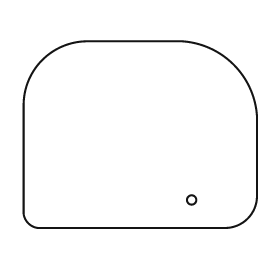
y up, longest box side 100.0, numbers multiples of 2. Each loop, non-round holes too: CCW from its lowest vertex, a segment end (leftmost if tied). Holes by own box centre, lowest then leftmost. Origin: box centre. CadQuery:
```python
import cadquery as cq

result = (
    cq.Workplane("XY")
    .moveTo(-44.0, -40.0)
    .lineTo(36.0, -40.0)
    .threePointArc((46.0, -36.0), (50.0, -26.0))
    .lineTo(50.0, 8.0)
    .threePointArc((40.0, 30.0), (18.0, 40.0))
    .lineTo(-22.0, 40.0)
    .threePointArc((-42.0, 32.0), (-50.0, 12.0))
    .lineTo(-50.0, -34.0)
    .threePointArc((-48.0, -38.0), (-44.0, -40.0))
    .close()
    .moveTo(22.0, -28.0)
    .circle(2.0)
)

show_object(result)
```